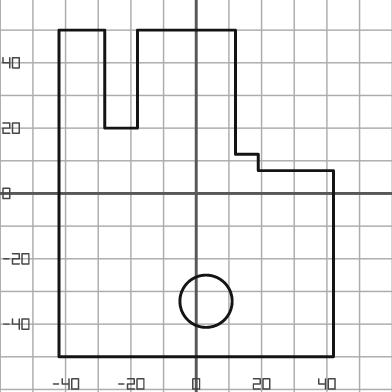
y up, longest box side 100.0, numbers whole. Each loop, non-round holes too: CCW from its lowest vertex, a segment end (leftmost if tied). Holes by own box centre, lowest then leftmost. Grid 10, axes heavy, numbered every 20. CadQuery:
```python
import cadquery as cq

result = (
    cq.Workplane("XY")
    .moveTo(-42.0, -50.0)
    .lineTo(42.0, -50.0)
    .lineTo(42.0, 7.0)
    .lineTo(19.0, 7.0)
    .lineTo(19.0, 12.0)
    .lineTo(12.0, 12.0)
    .lineTo(12.0, 50.0)
    .lineTo(-18.0, 50.0)
    .lineTo(-18.0, 20.0)
    .lineTo(-28.0, 20.0)
    .lineTo(-28.0, 50.0)
    .lineTo(-42.0, 50.0)
    .close()
    .moveTo(3.0, -33.0)
    .circle(8.0)
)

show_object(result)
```